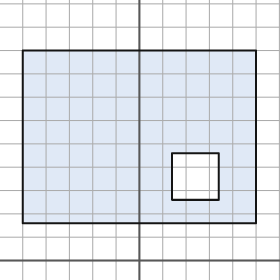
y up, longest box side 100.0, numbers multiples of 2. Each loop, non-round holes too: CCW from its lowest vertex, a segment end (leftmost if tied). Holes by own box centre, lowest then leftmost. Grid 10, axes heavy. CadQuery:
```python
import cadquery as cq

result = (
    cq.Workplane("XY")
    .moveTo(-50.0, 16.0)
    .lineTo(50.0, 16.0)
    .lineTo(50.0, 90.0)
    .lineTo(-50.0, 90.0)
    .close()
    .moveTo(14.0, 26.0)
    .lineTo(34.0, 26.0)
    .lineTo(34.0, 46.0)
    .lineTo(14.0, 46.0)
    .close()
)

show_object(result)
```